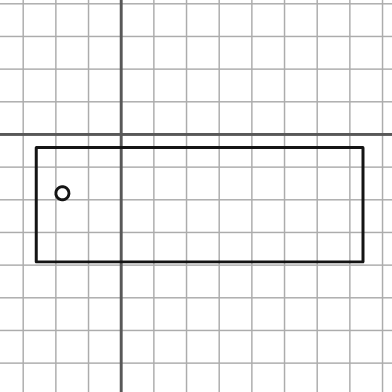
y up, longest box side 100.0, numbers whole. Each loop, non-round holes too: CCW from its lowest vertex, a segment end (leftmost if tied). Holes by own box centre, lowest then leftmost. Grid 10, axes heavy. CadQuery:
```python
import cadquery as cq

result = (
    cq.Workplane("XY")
    .moveTo(-26.0, -39.0)
    .lineTo(74.0, -39.0)
    .lineTo(74.0, -4.0)
    .lineTo(-26.0, -4.0)
    .close()
    .moveTo(-18.0, -18.0)
    .circle(2.0)
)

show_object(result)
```